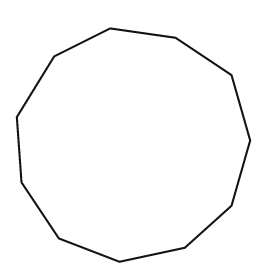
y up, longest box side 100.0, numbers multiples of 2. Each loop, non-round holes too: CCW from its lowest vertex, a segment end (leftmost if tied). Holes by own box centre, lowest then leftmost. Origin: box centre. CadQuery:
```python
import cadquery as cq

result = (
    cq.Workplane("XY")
    .moveTo(-6.0, -50.0)
    .lineTo(22.0, -44.0)
    .lineTo(42.0, -26.0)
    .lineTo(50.0, 2.0)
    .lineTo(42.0, 30.0)
    .lineTo(18.0, 46.0)
    .lineTo(-10.0, 50.0)
    .lineTo(-34.0, 38.0)
    .lineTo(-50.0, 12.0)
    .lineTo(-48.0, -16.0)
    .lineTo(-32.0, -40.0)
    .close()
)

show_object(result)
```